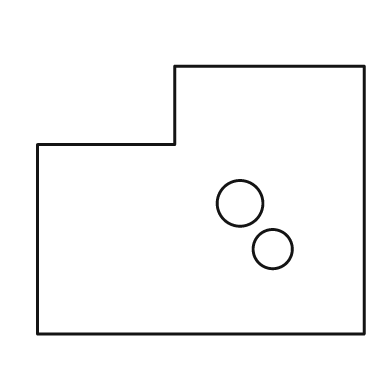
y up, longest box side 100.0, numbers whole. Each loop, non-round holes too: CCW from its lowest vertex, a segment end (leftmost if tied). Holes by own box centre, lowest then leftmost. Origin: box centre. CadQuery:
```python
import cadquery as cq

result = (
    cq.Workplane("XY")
    .moveTo(-50.0, -41.0)
    .lineTo(50.0, -41.0)
    .lineTo(50.0, 41.0)
    .lineTo(-8.0, 41.0)
    .lineTo(-8.0, 17.0)
    .lineTo(-50.0, 17.0)
    .close()
    .moveTo(22.0, -15.0)
    .circle(6.0)
    .moveTo(12.0, -1.0)
    .circle(7.0)
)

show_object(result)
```